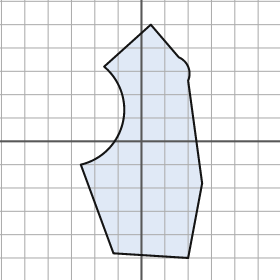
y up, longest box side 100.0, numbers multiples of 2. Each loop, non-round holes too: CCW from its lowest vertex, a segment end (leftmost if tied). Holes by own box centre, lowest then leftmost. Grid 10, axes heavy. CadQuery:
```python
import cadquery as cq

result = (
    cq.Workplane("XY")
    .moveTo(20.0, -50.0)
    .lineTo(26.0, -18.0)
    .lineTo(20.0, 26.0)
    .threePointArc((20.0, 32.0), (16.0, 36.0))
    .lineTo(4.0, 50.0)
    .lineTo(-16.0, 32.0)
    .threePointArc((-8.0, 8.0), (-26.0, -10.0))
    .lineTo(-12.0, -48.0)
    .close()
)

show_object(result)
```